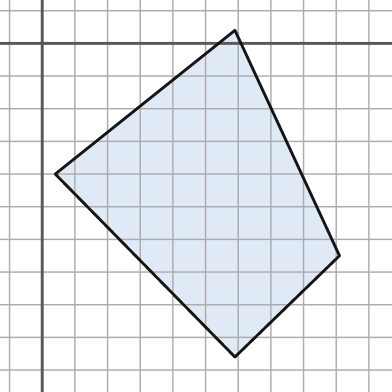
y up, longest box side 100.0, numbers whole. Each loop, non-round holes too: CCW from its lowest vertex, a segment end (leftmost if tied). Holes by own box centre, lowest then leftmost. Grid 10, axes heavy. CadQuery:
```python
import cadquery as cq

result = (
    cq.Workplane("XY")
    .moveTo(59.0, -96.0)
    .lineTo(91.0, -65.0)
    .lineTo(59.0, 4.0)
    .lineTo(4.0, -40.0)
    .close()
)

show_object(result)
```